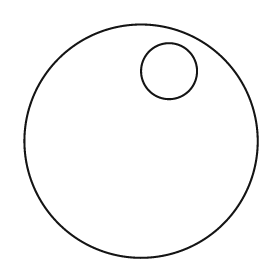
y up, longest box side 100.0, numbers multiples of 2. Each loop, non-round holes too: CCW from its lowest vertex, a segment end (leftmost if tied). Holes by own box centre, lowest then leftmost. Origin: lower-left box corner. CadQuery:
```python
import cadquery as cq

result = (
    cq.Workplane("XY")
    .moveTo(50.0, 50.0)
    .circle(50.0)
    .moveTo(62.0, 80.0)
    .circle(12.0)
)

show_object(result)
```